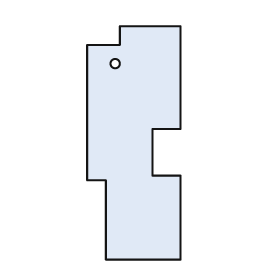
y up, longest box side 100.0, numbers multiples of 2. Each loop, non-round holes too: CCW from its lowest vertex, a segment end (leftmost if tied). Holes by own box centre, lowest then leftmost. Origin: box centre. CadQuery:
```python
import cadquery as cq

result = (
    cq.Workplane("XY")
    .moveTo(-12.0, -50.0)
    .lineTo(20.0, -50.0)
    .lineTo(20.0, -14.0)
    .lineTo(8.0, -14.0)
    .lineTo(8.0, 6.0)
    .lineTo(20.0, 6.0)
    .lineTo(20.0, 50.0)
    .lineTo(-6.0, 50.0)
    .lineTo(-6.0, 42.0)
    .lineTo(-20.0, 42.0)
    .lineTo(-20.0, -16.0)
    .lineTo(-12.0, -16.0)
    .close()
    .moveTo(-8.0, 34.0)
    .circle(2.0)
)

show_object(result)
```